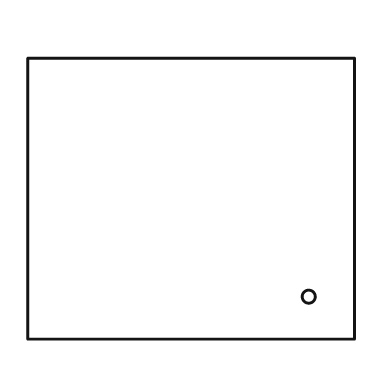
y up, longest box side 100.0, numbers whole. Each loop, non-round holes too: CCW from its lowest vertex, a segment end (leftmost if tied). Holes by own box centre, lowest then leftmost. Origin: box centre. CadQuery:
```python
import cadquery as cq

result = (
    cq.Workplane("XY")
    .moveTo(-50.0, -43.0)
    .lineTo(50.0, -43.0)
    .lineTo(50.0, 43.0)
    .lineTo(-50.0, 43.0)
    .close()
    .moveTo(36.0, -30.0)
    .circle(2.0)
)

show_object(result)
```